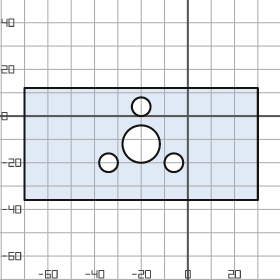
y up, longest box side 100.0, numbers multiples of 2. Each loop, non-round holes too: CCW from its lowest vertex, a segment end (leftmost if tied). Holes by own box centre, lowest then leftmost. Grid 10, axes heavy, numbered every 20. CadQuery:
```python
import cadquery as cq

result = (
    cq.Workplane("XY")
    .moveTo(-70.0, -36.0)
    .lineTo(30.0, -36.0)
    .lineTo(30.0, 12.0)
    .lineTo(-70.0, 12.0)
    .close()
    .moveTo(-34.0, -20.0)
    .circle(4.0)
    .moveTo(-6.0, -20.0)
    .circle(4.0)
    .moveTo(-20.0, -12.0)
    .circle(8.0)
    .moveTo(-20.0, 4.0)
    .circle(4.0)
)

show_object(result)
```